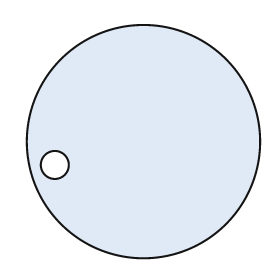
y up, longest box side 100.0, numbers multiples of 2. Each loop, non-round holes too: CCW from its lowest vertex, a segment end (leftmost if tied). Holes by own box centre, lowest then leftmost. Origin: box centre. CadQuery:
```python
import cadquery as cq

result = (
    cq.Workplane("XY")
    .moveTo(0.0, 0.0)
    .circle(50.0)
    .moveTo(-38.0, -10.0)
    .circle(6.0)
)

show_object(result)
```